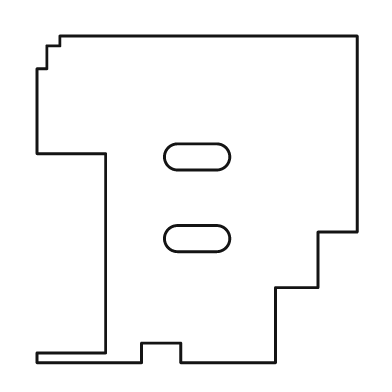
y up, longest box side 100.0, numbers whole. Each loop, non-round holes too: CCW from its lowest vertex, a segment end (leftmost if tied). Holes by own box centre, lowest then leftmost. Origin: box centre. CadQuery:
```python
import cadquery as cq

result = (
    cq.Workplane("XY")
    .moveTo(-49.0, -50.0)
    .lineTo(-17.0, -50.0)
    .lineTo(-17.0, -44.0)
    .lineTo(-5.0, -44.0)
    .lineTo(-5.0, -50.0)
    .lineTo(24.0, -50.0)
    .lineTo(24.0, -27.0)
    .lineTo(37.0, -27.0)
    .lineTo(37.0, -10.0)
    .lineTo(49.0, -10.0)
    .lineTo(49.0, 50.0)
    .lineTo(-42.0, 50.0)
    .lineTo(-42.0, 47.0)
    .lineTo(-46.0, 47.0)
    .lineTo(-46.0, 40.0)
    .lineTo(-49.0, 40.0)
    .lineTo(-49.0, 14.0)
    .lineTo(-28.0, 14.0)
    .lineTo(-28.0, -47.0)
    .lineTo(-49.0, -47.0)
    .close()
    .moveTo(-6.0, -16.0)
    .lineTo(6.0, -16.0)
    .threePointArc((10.0, -12.0), (6.0, -8.0))
    .lineTo(-6.0, -8.0)
    .threePointArc((-10.0, -12.0), (-6.0, -16.0))
    .close()
    .moveTo(-6.0, 9.0)
    .lineTo(6.0, 9.0)
    .threePointArc((10.0, 13.0), (6.0, 17.0))
    .lineTo(-6.0, 17.0)
    .threePointArc((-10.0, 13.0), (-6.0, 9.0))
    .close()
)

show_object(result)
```